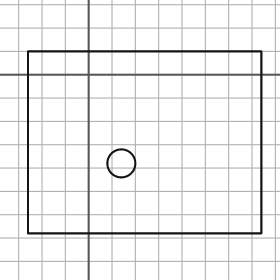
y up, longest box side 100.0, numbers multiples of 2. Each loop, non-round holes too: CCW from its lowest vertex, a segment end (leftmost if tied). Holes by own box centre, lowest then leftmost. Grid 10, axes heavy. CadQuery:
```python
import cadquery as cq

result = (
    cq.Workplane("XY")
    .moveTo(-26.0, -68.0)
    .lineTo(74.0, -68.0)
    .lineTo(74.0, 10.0)
    .lineTo(-26.0, 10.0)
    .close()
    .moveTo(14.0, -38.0)
    .circle(6.0)
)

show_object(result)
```